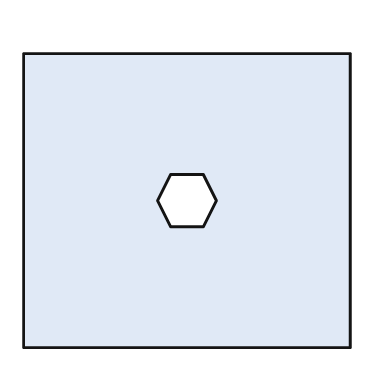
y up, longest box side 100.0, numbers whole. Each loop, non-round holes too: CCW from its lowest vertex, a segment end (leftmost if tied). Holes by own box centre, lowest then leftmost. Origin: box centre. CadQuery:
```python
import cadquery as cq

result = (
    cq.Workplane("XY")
    .moveTo(-50.0, -45.0)
    .lineTo(50.0, -45.0)
    .lineTo(50.0, 45.0)
    .lineTo(-50.0, 45.0)
    .close()
    .moveTo(-5.0, -8.0)
    .lineTo(5.0, -8.0)
    .lineTo(9.0, 0.0)
    .lineTo(5.0, 8.0)
    .lineTo(-5.0, 8.0)
    .lineTo(-9.0, 0.0)
    .close()
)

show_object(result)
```